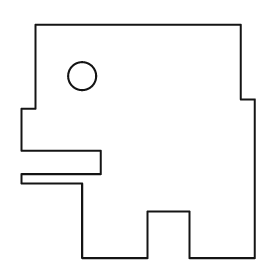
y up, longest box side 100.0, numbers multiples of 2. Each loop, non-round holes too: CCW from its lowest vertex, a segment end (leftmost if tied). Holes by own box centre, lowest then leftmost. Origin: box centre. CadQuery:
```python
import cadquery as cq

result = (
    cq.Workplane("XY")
    .moveTo(-24.0, -50.0)
    .lineTo(4.0, -50.0)
    .lineTo(4.0, -30.0)
    .lineTo(22.0, -30.0)
    .lineTo(22.0, -50.0)
    .lineTo(50.0, -50.0)
    .lineTo(50.0, 18.0)
    .lineTo(44.0, 18.0)
    .lineTo(44.0, 50.0)
    .lineTo(-44.0, 50.0)
    .lineTo(-44.0, 14.0)
    .lineTo(-50.0, 14.0)
    .lineTo(-50.0, -4.0)
    .lineTo(-16.0, -4.0)
    .lineTo(-16.0, -14.0)
    .lineTo(-50.0, -14.0)
    .lineTo(-50.0, -18.0)
    .lineTo(-24.0, -18.0)
    .close()
    .moveTo(-24.0, 28.0)
    .circle(6.0)
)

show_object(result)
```